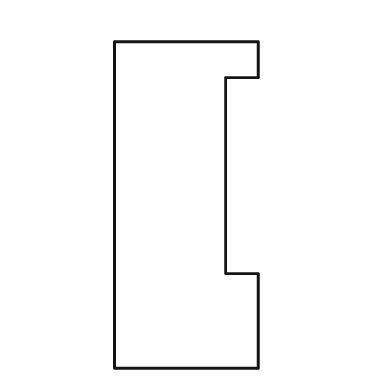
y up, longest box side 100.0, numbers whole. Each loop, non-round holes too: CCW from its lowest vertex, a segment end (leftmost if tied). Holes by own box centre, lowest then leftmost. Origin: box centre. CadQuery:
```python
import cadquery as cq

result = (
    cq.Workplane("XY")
    .moveTo(-22.0, -50.0)
    .lineTo(22.0, -50.0)
    .lineTo(22.0, -21.0)
    .lineTo(12.0, -21.0)
    .lineTo(12.0, 39.0)
    .lineTo(22.0, 39.0)
    .lineTo(22.0, 50.0)
    .lineTo(-22.0, 50.0)
    .close()
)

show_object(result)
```